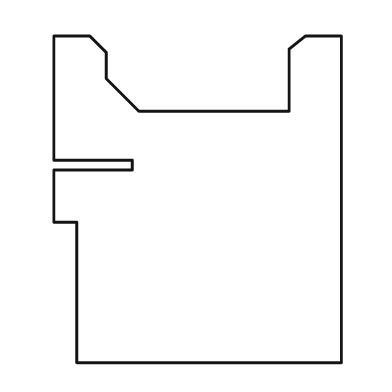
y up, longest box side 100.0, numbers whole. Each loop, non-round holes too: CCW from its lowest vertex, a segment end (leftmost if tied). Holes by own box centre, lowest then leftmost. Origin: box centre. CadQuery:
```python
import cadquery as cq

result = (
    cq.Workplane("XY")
    .moveTo(-37.0, -50.0)
    .lineTo(44.0, -50.0)
    .lineTo(44.0, 50.0)
    .lineTo(33.0, 50.0)
    .lineTo(28.0, 46.0)
    .lineTo(28.0, 27.0)
    .lineTo(-18.0, 27.0)
    .lineTo(-28.0, 37.0)
    .lineTo(-28.0, 45.0)
    .lineTo(-33.0, 50.0)
    .lineTo(-44.0, 50.0)
    .lineTo(-44.0, 12.0)
    .lineTo(-20.0, 12.0)
    .lineTo(-20.0, 9.0)
    .lineTo(-44.0, 9.0)
    .lineTo(-44.0, -7.0)
    .lineTo(-37.0, -7.0)
    .close()
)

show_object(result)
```